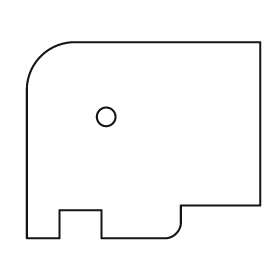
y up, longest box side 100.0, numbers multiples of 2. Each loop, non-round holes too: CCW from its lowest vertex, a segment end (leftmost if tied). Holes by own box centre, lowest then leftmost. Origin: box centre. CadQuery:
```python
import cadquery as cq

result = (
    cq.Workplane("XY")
    .moveTo(-50.0, -42.0)
    .lineTo(-36.0, -42.0)
    .lineTo(-36.0, -30.0)
    .lineTo(-18.0, -30.0)
    .lineTo(-18.0, -42.0)
    .lineTo(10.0, -42.0)
    .threePointArc((14.0, -40.0), (16.0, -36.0))
    .lineTo(16.0, -28.0)
    .lineTo(50.0, -28.0)
    .lineTo(50.0, 42.0)
    .lineTo(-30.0, 42.0)
    .threePointArc((-44.0, 36.0), (-50.0, 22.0))
    .close()
    .moveTo(-16.0, 10.0)
    .circle(4.0)
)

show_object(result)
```